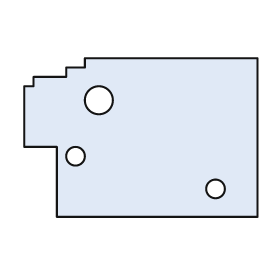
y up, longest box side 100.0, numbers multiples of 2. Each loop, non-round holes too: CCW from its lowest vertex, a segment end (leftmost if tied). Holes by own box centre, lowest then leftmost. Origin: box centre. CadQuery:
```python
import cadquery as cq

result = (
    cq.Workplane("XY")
    .moveTo(-36.0, -34.0)
    .lineTo(50.0, -34.0)
    .lineTo(50.0, 34.0)
    .lineTo(-24.0, 34.0)
    .lineTo(-24.0, 30.0)
    .lineTo(-32.0, 30.0)
    .lineTo(-32.0, 26.0)
    .lineTo(-46.0, 26.0)
    .lineTo(-46.0, 22.0)
    .lineTo(-50.0, 22.0)
    .lineTo(-50.0, -4.0)
    .lineTo(-36.0, -4.0)
    .close()
    .moveTo(32.0, -22.0)
    .circle(4.0)
    .moveTo(-28.0, -8.0)
    .circle(4.0)
    .moveTo(-18.0, 16.0)
    .circle(6.0)
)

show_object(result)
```